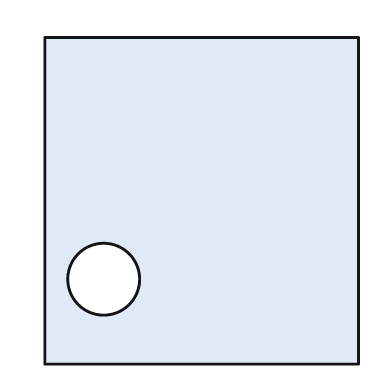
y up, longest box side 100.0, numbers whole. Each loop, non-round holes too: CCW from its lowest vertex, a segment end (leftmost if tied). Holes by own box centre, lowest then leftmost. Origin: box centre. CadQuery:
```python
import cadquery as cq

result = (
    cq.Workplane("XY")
    .moveTo(-48.0, -50.0)
    .lineTo(48.0, -50.0)
    .lineTo(48.0, 50.0)
    .lineTo(-48.0, 50.0)
    .close()
    .moveTo(-30.0, -24.0)
    .circle(11.0)
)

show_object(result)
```